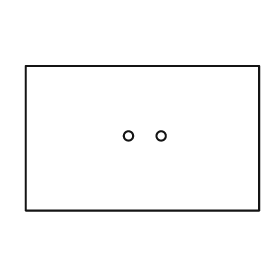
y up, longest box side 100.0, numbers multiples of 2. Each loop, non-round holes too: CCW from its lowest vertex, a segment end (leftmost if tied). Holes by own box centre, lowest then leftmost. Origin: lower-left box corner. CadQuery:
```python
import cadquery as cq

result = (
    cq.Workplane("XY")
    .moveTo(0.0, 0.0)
    .lineTo(100.0, 0.0)
    .lineTo(100.0, 62.0)
    .lineTo(0.0, 62.0)
    .close()
    .moveTo(44.0, 32.0)
    .circle(2.0)
    .moveTo(58.0, 32.0)
    .circle(2.0)
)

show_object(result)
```